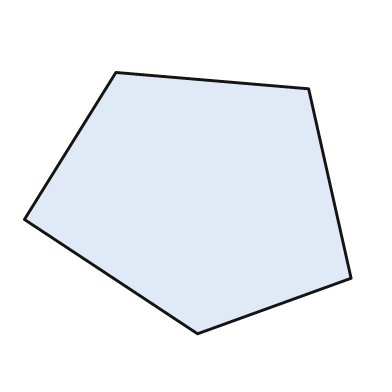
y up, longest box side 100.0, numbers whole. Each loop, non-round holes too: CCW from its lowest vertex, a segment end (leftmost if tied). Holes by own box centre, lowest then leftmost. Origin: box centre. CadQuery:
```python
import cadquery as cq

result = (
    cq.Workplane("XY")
    .moveTo(3.0, -40.0)
    .lineTo(50.0, -23.0)
    .lineTo(37.0, 35.0)
    .lineTo(-22.0, 40.0)
    .lineTo(-50.0, -5.0)
    .close()
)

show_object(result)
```